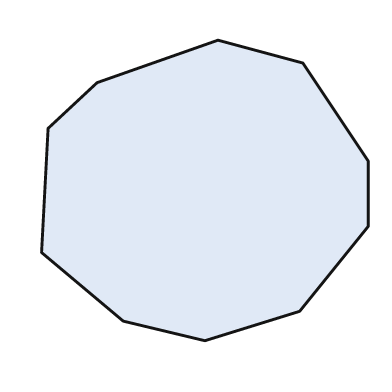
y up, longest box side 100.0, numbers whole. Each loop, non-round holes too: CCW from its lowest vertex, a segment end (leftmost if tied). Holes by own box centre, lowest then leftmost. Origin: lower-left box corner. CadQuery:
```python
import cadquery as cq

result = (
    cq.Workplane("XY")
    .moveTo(50.0, 0.0)
    .lineTo(79.0, 9.0)
    .lineTo(100.0, 35.0)
    .lineTo(100.0, 55.0)
    .lineTo(80.0, 85.0)
    .lineTo(54.0, 92.0)
    .lineTo(17.0, 79.0)
    .lineTo(2.0, 65.0)
    .lineTo(0.0, 27.0)
    .lineTo(25.0, 6.0)
    .close()
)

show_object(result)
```